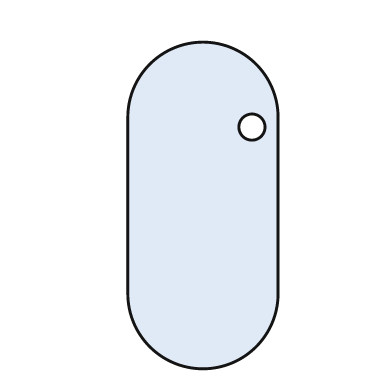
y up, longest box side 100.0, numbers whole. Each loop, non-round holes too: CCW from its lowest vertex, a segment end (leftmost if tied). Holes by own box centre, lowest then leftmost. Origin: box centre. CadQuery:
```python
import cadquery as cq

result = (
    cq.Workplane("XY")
    .moveTo(-23.0, -27.0)
    .threePointArc((0.0, -50.0), (23.0, -27.0))
    .lineTo(23.0, 27.0)
    .threePointArc((0.0, 50.0), (-23.0, 27.0))
    .close()
    .moveTo(15.0, 24.0)
    .circle(4.0)
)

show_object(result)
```